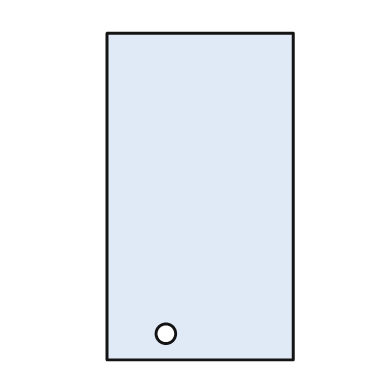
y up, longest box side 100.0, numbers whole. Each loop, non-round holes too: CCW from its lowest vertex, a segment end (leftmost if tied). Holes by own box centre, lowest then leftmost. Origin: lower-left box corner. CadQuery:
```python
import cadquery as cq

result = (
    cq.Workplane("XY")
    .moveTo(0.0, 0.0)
    .lineTo(57.0, 0.0)
    .lineTo(57.0, 100.0)
    .lineTo(0.0, 100.0)
    .close()
    .moveTo(18.0, 8.0)
    .circle(3.0)
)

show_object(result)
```